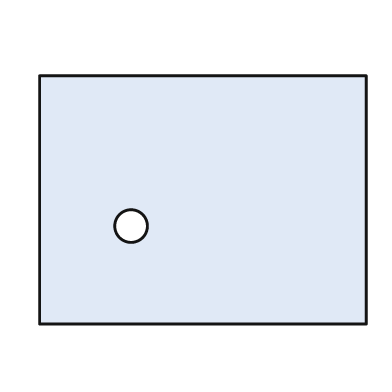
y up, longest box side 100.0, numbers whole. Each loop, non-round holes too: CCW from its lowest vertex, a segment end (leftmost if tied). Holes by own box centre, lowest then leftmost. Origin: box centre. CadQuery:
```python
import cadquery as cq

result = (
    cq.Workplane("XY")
    .moveTo(-50.0, -38.0)
    .lineTo(50.0, -38.0)
    .lineTo(50.0, 38.0)
    .lineTo(-50.0, 38.0)
    .close()
    .moveTo(-22.0, -8.0)
    .circle(5.0)
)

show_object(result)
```